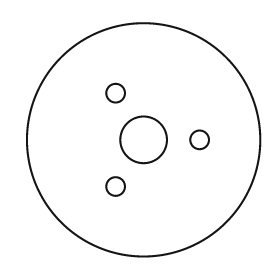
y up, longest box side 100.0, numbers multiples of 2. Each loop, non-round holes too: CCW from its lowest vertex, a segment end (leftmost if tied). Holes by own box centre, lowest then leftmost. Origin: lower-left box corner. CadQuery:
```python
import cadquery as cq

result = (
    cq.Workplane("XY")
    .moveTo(50.0, 50.0)
    .circle(50.0)
    .moveTo(38.0, 30.0)
    .circle(4.0)
    .moveTo(50.0, 50.0)
    .circle(10.0)
    .moveTo(74.0, 50.0)
    .circle(4.0)
    .moveTo(38.0, 70.0)
    .circle(4.0)
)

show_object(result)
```